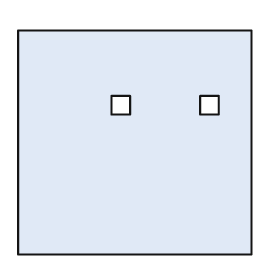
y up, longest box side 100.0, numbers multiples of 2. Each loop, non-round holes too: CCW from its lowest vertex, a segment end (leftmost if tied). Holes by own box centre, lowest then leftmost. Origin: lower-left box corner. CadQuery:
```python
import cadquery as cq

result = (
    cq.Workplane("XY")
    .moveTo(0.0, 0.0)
    .lineTo(100.0, 0.0)
    .lineTo(100.0, 96.0)
    .lineTo(0.0, 96.0)
    .close()
    .moveTo(40.0, 60.0)
    .lineTo(48.0, 60.0)
    .lineTo(48.0, 68.0)
    .lineTo(40.0, 68.0)
    .close()
    .moveTo(78.0, 60.0)
    .lineTo(86.0, 60.0)
    .lineTo(86.0, 68.0)
    .lineTo(78.0, 68.0)
    .close()
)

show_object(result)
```